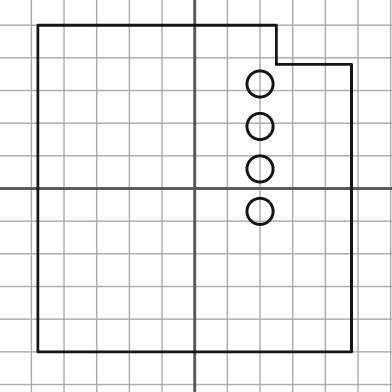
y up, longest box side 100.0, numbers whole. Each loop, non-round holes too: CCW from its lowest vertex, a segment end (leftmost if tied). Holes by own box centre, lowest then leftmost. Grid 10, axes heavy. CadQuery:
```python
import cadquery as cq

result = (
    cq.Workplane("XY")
    .moveTo(-48.0, -50.0)
    .lineTo(48.0, -50.0)
    .lineTo(48.0, 38.0)
    .lineTo(25.0, 38.0)
    .lineTo(25.0, 50.0)
    .lineTo(-48.0, 50.0)
    .close()
    .moveTo(20.0, -7.0)
    .circle(4.0)
    .moveTo(20.0, 6.0)
    .circle(4.0)
    .moveTo(20.0, 19.0)
    .circle(4.0)
    .moveTo(20.0, 32.0)
    .circle(4.0)
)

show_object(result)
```